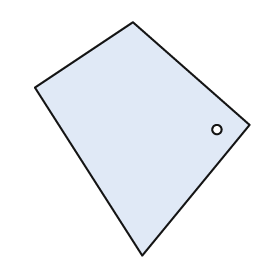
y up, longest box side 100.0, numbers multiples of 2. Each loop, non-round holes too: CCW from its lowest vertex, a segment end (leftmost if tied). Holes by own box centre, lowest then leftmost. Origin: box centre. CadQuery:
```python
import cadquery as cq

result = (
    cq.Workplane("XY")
    .moveTo(0.0, -50.0)
    .lineTo(46.0, 6.0)
    .lineTo(-4.0, 50.0)
    .lineTo(-46.0, 22.0)
    .close()
    .moveTo(32.0, 4.0)
    .circle(2.0)
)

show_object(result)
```